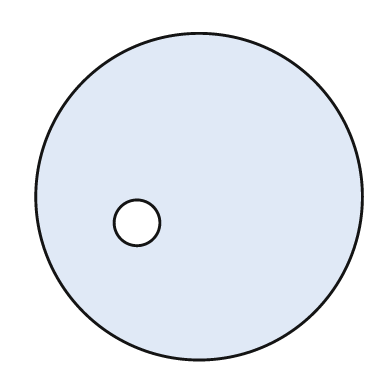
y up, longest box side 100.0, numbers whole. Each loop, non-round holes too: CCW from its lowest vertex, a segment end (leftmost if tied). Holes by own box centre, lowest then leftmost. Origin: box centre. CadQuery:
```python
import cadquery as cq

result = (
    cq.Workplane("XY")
    .moveTo(0.0, 0.0)
    .circle(50.0)
    .moveTo(-19.0, -8.0)
    .circle(7.0)
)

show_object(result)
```